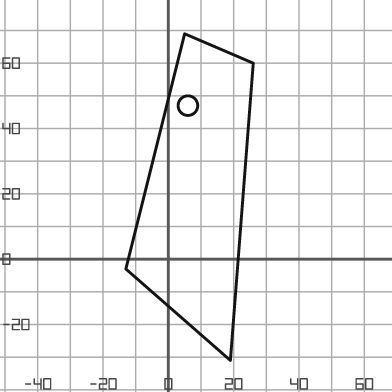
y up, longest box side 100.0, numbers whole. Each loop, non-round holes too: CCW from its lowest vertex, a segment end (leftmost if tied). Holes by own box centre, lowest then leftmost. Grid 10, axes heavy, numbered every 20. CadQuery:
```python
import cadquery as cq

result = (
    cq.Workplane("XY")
    .moveTo(19.0, -31.0)
    .lineTo(26.0, 60.0)
    .lineTo(5.0, 69.0)
    .lineTo(-13.0, -3.0)
    .close()
    .moveTo(6.0, 47.0)
    .circle(3.0)
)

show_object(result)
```